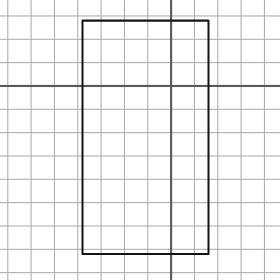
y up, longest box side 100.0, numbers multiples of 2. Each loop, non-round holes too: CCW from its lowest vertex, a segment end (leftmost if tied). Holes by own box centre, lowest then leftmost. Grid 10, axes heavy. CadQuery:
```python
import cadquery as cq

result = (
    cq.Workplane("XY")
    .moveTo(-38.0, -72.0)
    .lineTo(16.0, -72.0)
    .lineTo(16.0, 28.0)
    .lineTo(-38.0, 28.0)
    .close()
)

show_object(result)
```